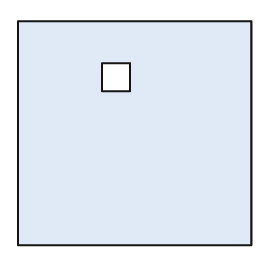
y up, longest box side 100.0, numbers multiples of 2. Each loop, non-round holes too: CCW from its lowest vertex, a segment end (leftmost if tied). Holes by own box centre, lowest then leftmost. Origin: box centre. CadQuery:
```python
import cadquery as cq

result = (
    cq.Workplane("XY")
    .moveTo(-50.0, -48.0)
    .lineTo(50.0, -48.0)
    .lineTo(50.0, 48.0)
    .lineTo(-50.0, 48.0)
    .close()
    .moveTo(-14.0, 18.0)
    .lineTo(-2.0, 18.0)
    .lineTo(-2.0, 30.0)
    .lineTo(-14.0, 30.0)
    .close()
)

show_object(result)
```